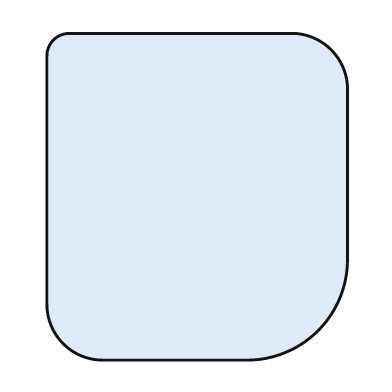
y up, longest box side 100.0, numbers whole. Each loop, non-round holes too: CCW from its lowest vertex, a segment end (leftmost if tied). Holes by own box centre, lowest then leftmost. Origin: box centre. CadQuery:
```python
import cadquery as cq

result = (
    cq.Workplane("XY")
    .moveTo(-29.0, -50.0)
    .lineTo(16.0, -50.0)
    .threePointArc((37.0, -41.0), (46.0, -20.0))
    .lineTo(46.0, 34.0)
    .threePointArc((41.0, 45.0), (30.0, 50.0))
    .lineTo(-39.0, 50.0)
    .threePointArc((-44.0, 48.0), (-46.0, 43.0))
    .lineTo(-46.0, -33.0)
    .threePointArc((-41.0, -45.0), (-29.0, -50.0))
    .close()
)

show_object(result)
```